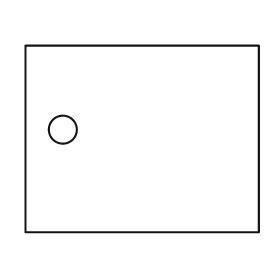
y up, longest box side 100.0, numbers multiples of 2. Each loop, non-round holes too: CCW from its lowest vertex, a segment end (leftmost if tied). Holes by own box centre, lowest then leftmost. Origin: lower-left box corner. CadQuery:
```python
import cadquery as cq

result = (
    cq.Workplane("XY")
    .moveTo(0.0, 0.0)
    .lineTo(100.0, 0.0)
    .lineTo(100.0, 80.0)
    .lineTo(0.0, 80.0)
    .close()
    .moveTo(16.0, 44.0)
    .circle(6.0)
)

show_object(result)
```